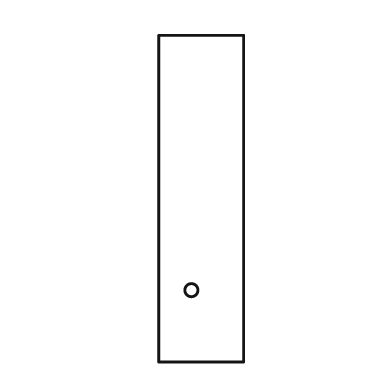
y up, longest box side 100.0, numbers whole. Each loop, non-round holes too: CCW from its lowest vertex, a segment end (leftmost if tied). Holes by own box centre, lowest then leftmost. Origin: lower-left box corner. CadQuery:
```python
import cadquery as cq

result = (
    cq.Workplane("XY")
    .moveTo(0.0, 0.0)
    .lineTo(26.0, 0.0)
    .lineTo(26.0, 100.0)
    .lineTo(0.0, 100.0)
    .close()
    .moveTo(10.0, 22.0)
    .circle(2.0)
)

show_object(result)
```